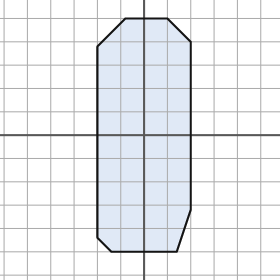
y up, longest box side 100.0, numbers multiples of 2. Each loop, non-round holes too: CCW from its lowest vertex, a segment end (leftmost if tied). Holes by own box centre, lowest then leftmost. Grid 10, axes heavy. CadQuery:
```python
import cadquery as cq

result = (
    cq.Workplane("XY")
    .moveTo(-14.0, -50.0)
    .lineTo(14.0, -50.0)
    .lineTo(20.0, -32.0)
    .lineTo(20.0, 40.0)
    .lineTo(10.0, 50.0)
    .lineTo(-8.0, 50.0)
    .lineTo(-20.0, 38.0)
    .lineTo(-20.0, -44.0)
    .close()
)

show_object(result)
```